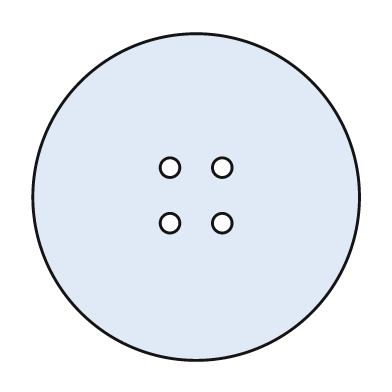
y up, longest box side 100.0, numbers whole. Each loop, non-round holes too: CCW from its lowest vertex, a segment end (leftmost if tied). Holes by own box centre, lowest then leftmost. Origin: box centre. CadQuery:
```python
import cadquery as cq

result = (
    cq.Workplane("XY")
    .moveTo(0.0, 0.0)
    .circle(50.0)
    .moveTo(-8.0, -8.0)
    .circle(3.0)
    .moveTo(8.0, -8.0)
    .circle(3.0)
    .moveTo(-8.0, 9.0)
    .circle(3.0)
    .moveTo(8.0, 9.0)
    .circle(3.0)
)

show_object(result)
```